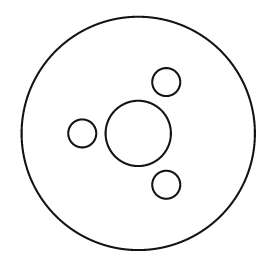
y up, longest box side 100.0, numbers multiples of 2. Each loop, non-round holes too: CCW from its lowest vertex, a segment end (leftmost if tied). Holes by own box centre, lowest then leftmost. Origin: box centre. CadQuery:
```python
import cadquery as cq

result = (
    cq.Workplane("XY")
    .moveTo(0.0, 0.0)
    .circle(50.0)
    .moveTo(12.0, -22.0)
    .circle(6.0)
    .moveTo(-24.0, 0.0)
    .circle(6.0)
    .moveTo(0.0, 0.0)
    .circle(14.0)
    .moveTo(12.0, 22.0)
    .circle(6.0)
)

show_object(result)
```